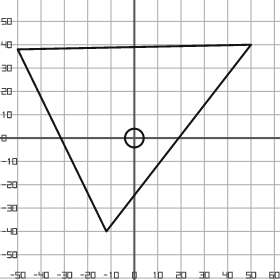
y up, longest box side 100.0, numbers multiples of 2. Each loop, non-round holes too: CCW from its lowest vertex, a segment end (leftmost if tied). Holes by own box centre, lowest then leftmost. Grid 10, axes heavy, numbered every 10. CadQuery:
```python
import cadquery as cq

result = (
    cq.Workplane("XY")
    .moveTo(-12.0, -40.0)
    .lineTo(50.0, 40.0)
    .lineTo(-50.0, 38.0)
    .close()
    .moveTo(0.0, 0.0)
    .circle(4.0)
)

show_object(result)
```